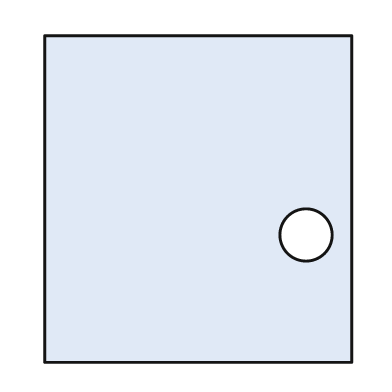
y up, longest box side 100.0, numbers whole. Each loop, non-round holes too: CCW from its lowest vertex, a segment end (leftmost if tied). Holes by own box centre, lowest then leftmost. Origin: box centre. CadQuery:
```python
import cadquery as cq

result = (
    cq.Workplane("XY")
    .moveTo(-47.0, -50.0)
    .lineTo(47.0, -50.0)
    .lineTo(47.0, 50.0)
    .lineTo(-47.0, 50.0)
    .close()
    .moveTo(33.0, -11.0)
    .circle(8.0)
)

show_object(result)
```